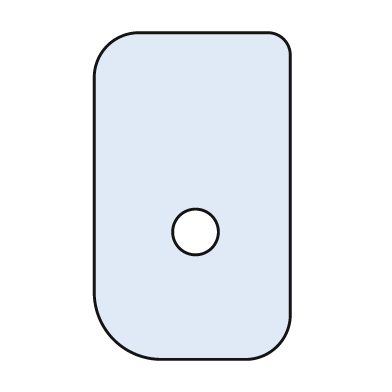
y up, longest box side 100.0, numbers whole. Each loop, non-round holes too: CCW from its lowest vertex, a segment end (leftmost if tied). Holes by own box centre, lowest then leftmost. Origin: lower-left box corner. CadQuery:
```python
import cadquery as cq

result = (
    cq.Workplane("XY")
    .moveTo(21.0, 0.0)
    .lineTo(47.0, 0.0)
    .threePointArc((56.0, 4.0), (60.0, 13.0))
    .lineTo(60.0, 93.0)
    .threePointArc((58.0, 98.0), (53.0, 100.0))
    .lineTo(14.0, 100.0)
    .threePointArc((4.0, 96.0), (0.0, 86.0))
    .lineTo(0.0, 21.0)
    .threePointArc((6.0, 6.0), (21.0, 0.0))
    .close()
    .moveTo(31.0, 39.0)
    .circle(7.0)
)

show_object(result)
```